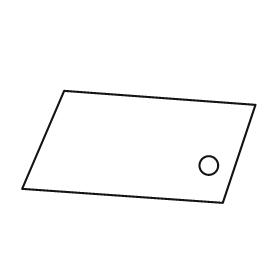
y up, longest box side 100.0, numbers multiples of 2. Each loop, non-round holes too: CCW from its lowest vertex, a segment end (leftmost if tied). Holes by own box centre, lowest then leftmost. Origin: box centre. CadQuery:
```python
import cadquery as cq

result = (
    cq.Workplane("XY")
    .moveTo(36.0, -24.0)
    .lineTo(50.0, 18.0)
    .lineTo(-32.0, 24.0)
    .lineTo(-50.0, -18.0)
    .close()
    .moveTo(30.0, -8.0)
    .circle(4.0)
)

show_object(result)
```